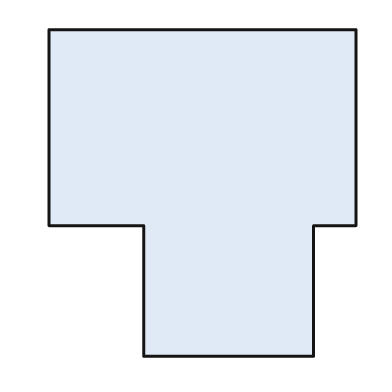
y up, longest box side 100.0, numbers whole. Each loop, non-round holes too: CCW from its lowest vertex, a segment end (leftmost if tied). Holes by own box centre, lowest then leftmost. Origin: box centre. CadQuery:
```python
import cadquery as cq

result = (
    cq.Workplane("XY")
    .moveTo(-18.0, -50.0)
    .lineTo(34.0, -50.0)
    .lineTo(34.0, -10.0)
    .lineTo(47.0, -10.0)
    .lineTo(47.0, 50.0)
    .lineTo(-47.0, 50.0)
    .lineTo(-47.0, -10.0)
    .lineTo(-18.0, -10.0)
    .close()
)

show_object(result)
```